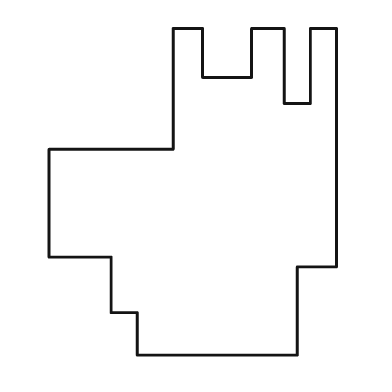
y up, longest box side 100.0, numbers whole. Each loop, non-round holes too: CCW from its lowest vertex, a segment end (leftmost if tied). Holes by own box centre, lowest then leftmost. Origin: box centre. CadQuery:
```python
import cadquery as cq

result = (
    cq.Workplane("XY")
    .moveTo(-17.0, -50.0)
    .lineTo(32.0, -50.0)
    .lineTo(32.0, -23.0)
    .lineTo(44.0, -23.0)
    .lineTo(44.0, 50.0)
    .lineTo(36.0, 50.0)
    .lineTo(36.0, 27.0)
    .lineTo(28.0, 27.0)
    .lineTo(28.0, 50.0)
    .lineTo(18.0, 50.0)
    .lineTo(18.0, 35.0)
    .lineTo(3.0, 35.0)
    .lineTo(3.0, 50.0)
    .lineTo(-6.0, 50.0)
    .lineTo(-6.0, 13.0)
    .lineTo(-44.0, 13.0)
    .lineTo(-44.0, -20.0)
    .lineTo(-25.0, -20.0)
    .lineTo(-25.0, -37.0)
    .lineTo(-17.0, -37.0)
    .close()
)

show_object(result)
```